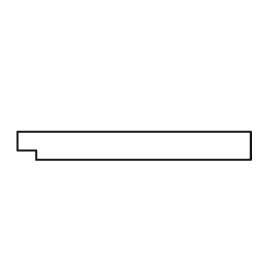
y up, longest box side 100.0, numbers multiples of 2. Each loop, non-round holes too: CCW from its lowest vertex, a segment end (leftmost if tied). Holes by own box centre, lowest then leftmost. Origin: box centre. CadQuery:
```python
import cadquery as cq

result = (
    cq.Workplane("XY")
    .moveTo(-42.0, -6.0)
    .lineTo(50.0, -6.0)
    .lineTo(50.0, 6.0)
    .lineTo(-50.0, 6.0)
    .lineTo(-50.0, -2.0)
    .lineTo(-42.0, -2.0)
    .close()
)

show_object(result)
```